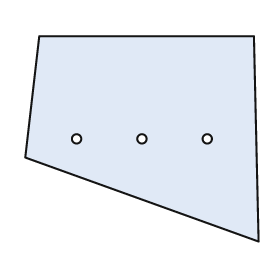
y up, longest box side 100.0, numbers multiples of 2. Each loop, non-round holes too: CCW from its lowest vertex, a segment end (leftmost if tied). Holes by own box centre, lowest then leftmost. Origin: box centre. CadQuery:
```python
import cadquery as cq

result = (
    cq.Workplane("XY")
    .moveTo(50.0, -44.0)
    .lineTo(48.0, 44.0)
    .lineTo(-44.0, 44.0)
    .lineTo(-50.0, -8.0)
    .close()
    .moveTo(-28.0, 0.0)
    .circle(2.0)
    .moveTo(0.0, 0.0)
    .circle(2.0)
    .moveTo(28.0, 0.0)
    .circle(2.0)
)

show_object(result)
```